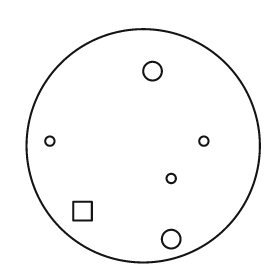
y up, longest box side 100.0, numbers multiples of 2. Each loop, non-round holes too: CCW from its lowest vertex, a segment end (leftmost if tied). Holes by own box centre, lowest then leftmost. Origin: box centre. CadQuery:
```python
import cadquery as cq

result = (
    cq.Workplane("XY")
    .moveTo(0.0, 0.0)
    .circle(50.0)
    .moveTo(12.0, -40.0)
    .circle(4.0)
    .moveTo(-30.0, -32.0)
    .lineTo(-22.0, -32.0)
    .lineTo(-22.0, -24.0)
    .lineTo(-30.0, -24.0)
    .close()
    .moveTo(12.0, -14.0)
    .circle(2.0)
    .moveTo(-40.0, 2.0)
    .circle(2.0)
    .moveTo(26.0, 2.0)
    .circle(2.0)
    .moveTo(4.0, 32.0)
    .circle(4.0)
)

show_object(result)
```